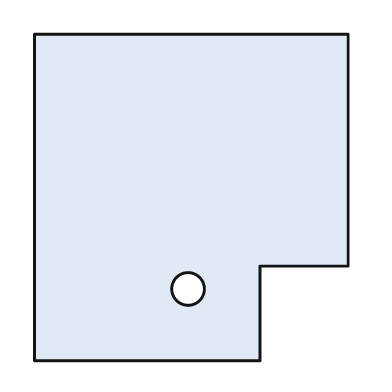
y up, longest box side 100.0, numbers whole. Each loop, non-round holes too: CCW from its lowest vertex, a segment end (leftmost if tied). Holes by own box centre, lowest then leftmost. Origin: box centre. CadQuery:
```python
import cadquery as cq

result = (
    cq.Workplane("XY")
    .moveTo(-48.0, -50.0)
    .lineTo(21.0, -50.0)
    .lineTo(21.0, -21.0)
    .lineTo(48.0, -21.0)
    .lineTo(48.0, 50.0)
    .lineTo(-48.0, 50.0)
    .close()
    .moveTo(-1.0, -28.0)
    .circle(5.0)
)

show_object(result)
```